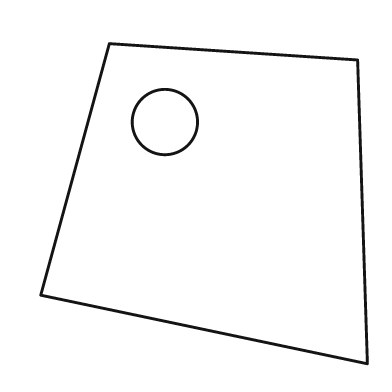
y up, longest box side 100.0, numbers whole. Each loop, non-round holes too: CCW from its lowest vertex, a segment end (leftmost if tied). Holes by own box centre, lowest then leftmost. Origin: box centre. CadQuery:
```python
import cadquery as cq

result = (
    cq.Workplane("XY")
    .moveTo(50.0, -49.0)
    .lineTo(47.0, 44.0)
    .lineTo(-29.0, 49.0)
    .lineTo(-50.0, -28.0)
    .close()
    .moveTo(-12.0, 25.0)
    .circle(10.0)
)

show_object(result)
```